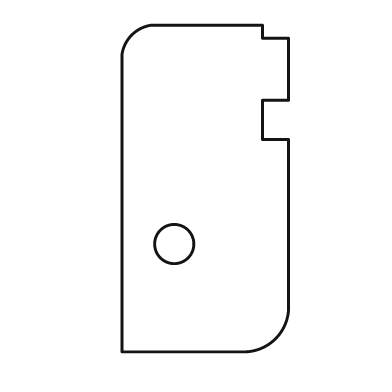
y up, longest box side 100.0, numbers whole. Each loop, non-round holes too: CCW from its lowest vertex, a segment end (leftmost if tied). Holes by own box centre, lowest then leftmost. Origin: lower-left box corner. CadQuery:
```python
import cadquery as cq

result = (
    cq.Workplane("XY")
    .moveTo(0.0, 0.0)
    .lineTo(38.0, 0.0)
    .threePointArc((47.0, 4.0), (51.0, 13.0))
    .lineTo(51.0, 65.0)
    .lineTo(43.0, 65.0)
    .lineTo(43.0, 77.0)
    .lineTo(51.0, 77.0)
    .lineTo(51.0, 96.0)
    .lineTo(43.0, 96.0)
    .lineTo(43.0, 100.0)
    .lineTo(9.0, 100.0)
    .threePointArc((3.0, 97.0), (0.0, 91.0))
    .close()
    .moveTo(16.0, 33.0)
    .circle(6.0)
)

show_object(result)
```